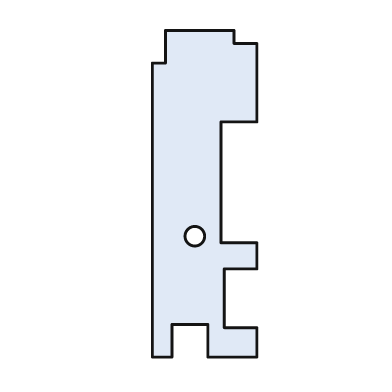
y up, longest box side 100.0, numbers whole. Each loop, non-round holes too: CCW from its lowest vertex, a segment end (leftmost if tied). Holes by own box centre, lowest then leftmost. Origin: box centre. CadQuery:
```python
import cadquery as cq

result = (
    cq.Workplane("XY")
    .moveTo(-16.0, -50.0)
    .lineTo(-10.0, -50.0)
    .lineTo(-10.0, -40.0)
    .lineTo(1.0, -40.0)
    .lineTo(1.0, -50.0)
    .lineTo(16.0, -50.0)
    .lineTo(16.0, -41.0)
    .lineTo(6.0, -41.0)
    .lineTo(6.0, -23.0)
    .lineTo(16.0, -23.0)
    .lineTo(16.0, -15.0)
    .lineTo(5.0, -15.0)
    .lineTo(5.0, 22.0)
    .lineTo(16.0, 22.0)
    .lineTo(16.0, 46.0)
    .lineTo(9.0, 46.0)
    .lineTo(9.0, 50.0)
    .lineTo(-12.0, 50.0)
    .lineTo(-12.0, 40.0)
    .lineTo(-16.0, 40.0)
    .close()
    .moveTo(-3.0, -13.0)
    .circle(3.0)
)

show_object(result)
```